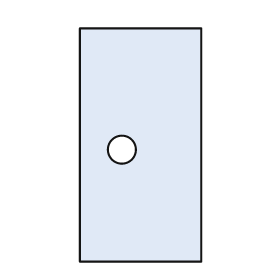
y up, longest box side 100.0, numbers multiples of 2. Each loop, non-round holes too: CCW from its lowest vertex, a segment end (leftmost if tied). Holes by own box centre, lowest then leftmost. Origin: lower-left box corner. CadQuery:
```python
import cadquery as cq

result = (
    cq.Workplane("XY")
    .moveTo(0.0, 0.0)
    .lineTo(52.0, 0.0)
    .lineTo(52.0, 100.0)
    .lineTo(0.0, 100.0)
    .close()
    .moveTo(18.0, 48.0)
    .circle(6.0)
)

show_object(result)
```